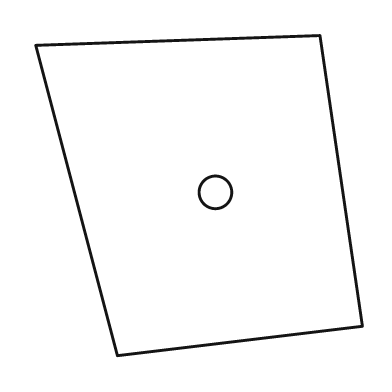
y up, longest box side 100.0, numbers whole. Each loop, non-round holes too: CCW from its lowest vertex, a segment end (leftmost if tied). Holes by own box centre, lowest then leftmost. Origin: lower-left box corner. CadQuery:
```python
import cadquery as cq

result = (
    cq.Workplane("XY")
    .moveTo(25.0, 0.0)
    .lineTo(100.0, 9.0)
    .lineTo(87.0, 98.0)
    .lineTo(0.0, 95.0)
    .close()
    .moveTo(55.0, 50.0)
    .circle(5.0)
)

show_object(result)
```